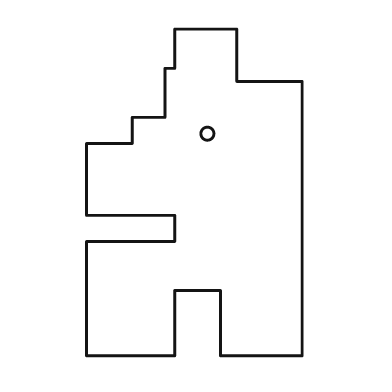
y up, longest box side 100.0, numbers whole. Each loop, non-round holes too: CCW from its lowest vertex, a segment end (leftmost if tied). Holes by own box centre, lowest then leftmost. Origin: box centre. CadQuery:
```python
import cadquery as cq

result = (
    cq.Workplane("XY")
    .moveTo(-33.0, -50.0)
    .lineTo(-6.0, -50.0)
    .lineTo(-6.0, -30.0)
    .lineTo(8.0, -30.0)
    .lineTo(8.0, -50.0)
    .lineTo(33.0, -50.0)
    .lineTo(33.0, 34.0)
    .lineTo(13.0, 34.0)
    .lineTo(13.0, 50.0)
    .lineTo(-6.0, 50.0)
    .lineTo(-6.0, 38.0)
    .lineTo(-9.0, 38.0)
    .lineTo(-9.0, 23.0)
    .lineTo(-19.0, 23.0)
    .lineTo(-19.0, 15.0)
    .lineTo(-33.0, 15.0)
    .lineTo(-33.0, -7.0)
    .lineTo(-6.0, -7.0)
    .lineTo(-6.0, -15.0)
    .lineTo(-33.0, -15.0)
    .close()
    .moveTo(4.0, 18.0)
    .circle(2.0)
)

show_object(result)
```